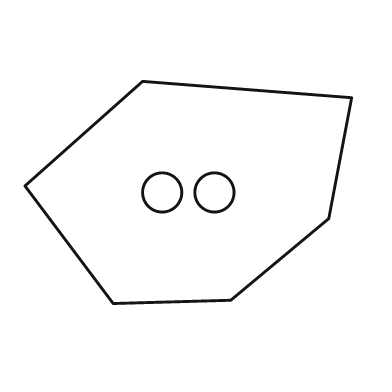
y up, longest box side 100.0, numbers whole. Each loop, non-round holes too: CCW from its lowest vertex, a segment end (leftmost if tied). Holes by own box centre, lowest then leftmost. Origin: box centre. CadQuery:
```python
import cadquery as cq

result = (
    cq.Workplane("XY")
    .moveTo(-23.0, -34.0)
    .lineTo(13.0, -33.0)
    .lineTo(43.0, -8.0)
    .lineTo(50.0, 29.0)
    .lineTo(-14.0, 34.0)
    .lineTo(-50.0, 2.0)
    .close()
    .moveTo(-8.0, 0.0)
    .circle(6.0)
    .moveTo(8.0, 0.0)
    .circle(6.0)
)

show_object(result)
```